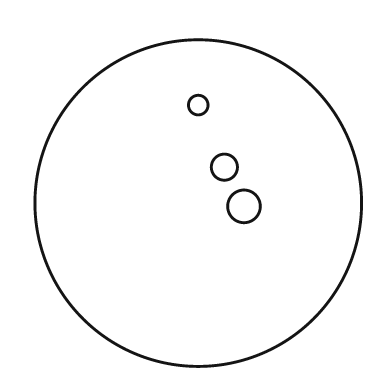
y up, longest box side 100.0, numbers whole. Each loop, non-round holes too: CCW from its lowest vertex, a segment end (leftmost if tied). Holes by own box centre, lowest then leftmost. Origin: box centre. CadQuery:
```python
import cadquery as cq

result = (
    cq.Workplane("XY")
    .moveTo(0.0, 0.0)
    .circle(50.0)
    .moveTo(14.0, -1.0)
    .circle(5.0)
    .moveTo(8.0, 11.0)
    .circle(4.0)
    .moveTo(0.0, 30.0)
    .circle(3.0)
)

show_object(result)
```